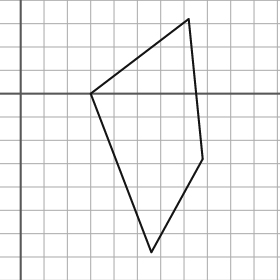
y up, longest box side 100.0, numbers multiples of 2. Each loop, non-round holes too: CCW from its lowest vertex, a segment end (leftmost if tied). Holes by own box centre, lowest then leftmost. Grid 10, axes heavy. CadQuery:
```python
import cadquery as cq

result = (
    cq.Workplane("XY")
    .moveTo(56.0, -68.0)
    .lineTo(78.0, -28.0)
    .lineTo(72.0, 32.0)
    .lineTo(30.0, 0.0)
    .close()
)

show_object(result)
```